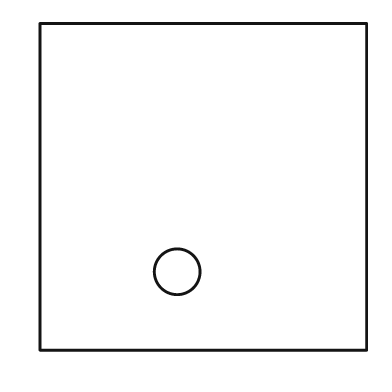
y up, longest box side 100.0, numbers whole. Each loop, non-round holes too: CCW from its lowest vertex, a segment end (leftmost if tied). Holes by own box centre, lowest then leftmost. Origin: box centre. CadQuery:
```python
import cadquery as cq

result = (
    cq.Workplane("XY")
    .moveTo(-50.0, -50.0)
    .lineTo(50.0, -50.0)
    .lineTo(50.0, 50.0)
    .lineTo(-50.0, 50.0)
    .close()
    .moveTo(-8.0, -26.0)
    .circle(7.0)
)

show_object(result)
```